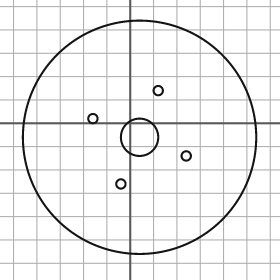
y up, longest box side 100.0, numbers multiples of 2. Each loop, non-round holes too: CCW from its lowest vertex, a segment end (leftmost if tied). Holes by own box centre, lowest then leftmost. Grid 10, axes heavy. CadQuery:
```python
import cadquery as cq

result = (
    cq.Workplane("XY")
    .moveTo(4.0, -6.0)
    .circle(50.0)
    .moveTo(-4.0, -26.0)
    .circle(2.0)
    .moveTo(24.0, -14.0)
    .circle(2.0)
    .moveTo(4.0, -6.0)
    .circle(8.0)
    .moveTo(-16.0, 2.0)
    .circle(2.0)
    .moveTo(12.0, 14.0)
    .circle(2.0)
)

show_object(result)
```